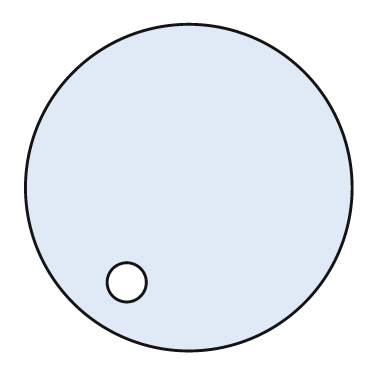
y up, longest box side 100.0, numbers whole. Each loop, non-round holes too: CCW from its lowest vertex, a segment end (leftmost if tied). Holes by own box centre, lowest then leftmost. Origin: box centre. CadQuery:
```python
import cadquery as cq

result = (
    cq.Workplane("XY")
    .moveTo(0.0, 0.0)
    .circle(50.0)
    .moveTo(-19.0, -29.0)
    .circle(6.0)
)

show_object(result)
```